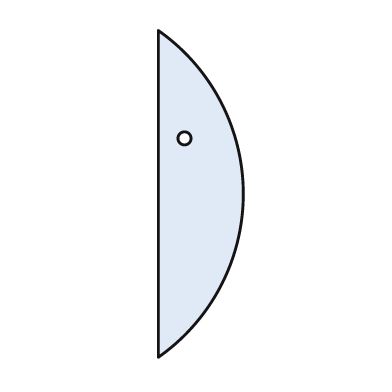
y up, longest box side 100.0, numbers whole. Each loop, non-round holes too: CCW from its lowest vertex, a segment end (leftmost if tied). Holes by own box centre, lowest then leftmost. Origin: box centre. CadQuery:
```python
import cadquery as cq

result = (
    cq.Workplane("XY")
    .moveTo(-13.0, -50.0)
    .threePointArc((13.0, 0.0), (-13.0, 50.0))
    .close()
    .moveTo(-5.0, 17.0)
    .circle(2.0)
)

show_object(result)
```